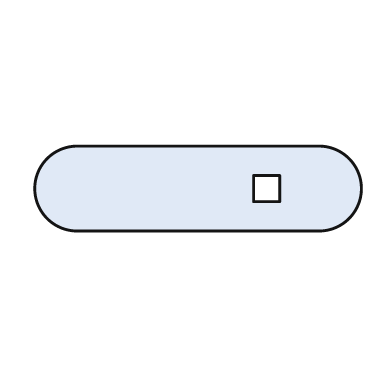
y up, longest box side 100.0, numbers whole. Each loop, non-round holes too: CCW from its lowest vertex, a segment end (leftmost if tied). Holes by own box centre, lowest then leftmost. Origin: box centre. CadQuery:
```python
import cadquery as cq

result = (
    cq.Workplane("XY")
    .moveTo(-37.0, -13.0)
    .lineTo(37.0, -13.0)
    .threePointArc((50.0, 0.0), (37.0, 13.0))
    .lineTo(-37.0, 13.0)
    .threePointArc((-50.0, 0.0), (-37.0, -13.0))
    .close()
    .moveTo(17.0, -4.0)
    .lineTo(25.0, -4.0)
    .lineTo(25.0, 4.0)
    .lineTo(17.0, 4.0)
    .close()
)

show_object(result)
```